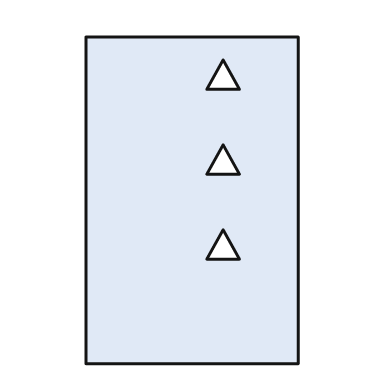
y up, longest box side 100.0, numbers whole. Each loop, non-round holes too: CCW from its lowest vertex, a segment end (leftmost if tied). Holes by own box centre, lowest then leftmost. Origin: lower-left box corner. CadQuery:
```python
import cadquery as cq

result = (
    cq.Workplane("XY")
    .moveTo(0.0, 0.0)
    .lineTo(65.0, 0.0)
    .lineTo(65.0, 100.0)
    .lineTo(0.0, 100.0)
    .close()
    .moveTo(37.0, 32.0)
    .lineTo(47.0, 32.0)
    .lineTo(42.0, 41.0)
    .close()
    .moveTo(37.0, 58.0)
    .lineTo(47.0, 58.0)
    .lineTo(42.0, 67.0)
    .close()
    .moveTo(37.0, 84.0)
    .lineTo(47.0, 84.0)
    .lineTo(42.0, 93.0)
    .close()
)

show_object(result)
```